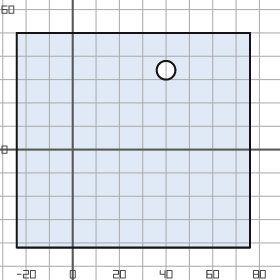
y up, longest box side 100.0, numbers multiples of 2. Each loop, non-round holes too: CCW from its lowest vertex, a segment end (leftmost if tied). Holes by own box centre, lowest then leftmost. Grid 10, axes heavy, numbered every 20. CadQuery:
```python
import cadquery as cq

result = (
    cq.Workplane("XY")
    .moveTo(-24.0, -42.0)
    .lineTo(76.0, -42.0)
    .lineTo(76.0, 50.0)
    .lineTo(-24.0, 50.0)
    .close()
    .moveTo(40.0, 34.0)
    .circle(4.0)
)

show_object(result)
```